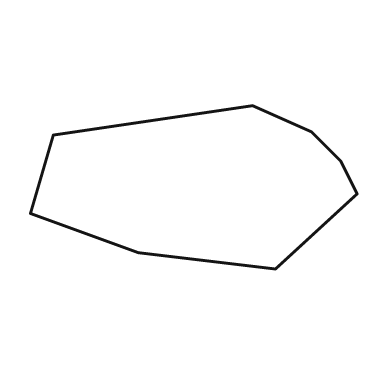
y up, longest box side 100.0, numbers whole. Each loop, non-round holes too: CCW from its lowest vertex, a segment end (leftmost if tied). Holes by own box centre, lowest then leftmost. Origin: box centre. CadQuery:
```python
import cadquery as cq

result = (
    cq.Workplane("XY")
    .moveTo(25.0, -25.0)
    .lineTo(50.0, -2.0)
    .lineTo(45.0, 8.0)
    .lineTo(36.0, 17.0)
    .lineTo(18.0, 25.0)
    .lineTo(-43.0, 16.0)
    .lineTo(-50.0, -8.0)
    .lineTo(-17.0, -20.0)
    .close()
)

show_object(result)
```